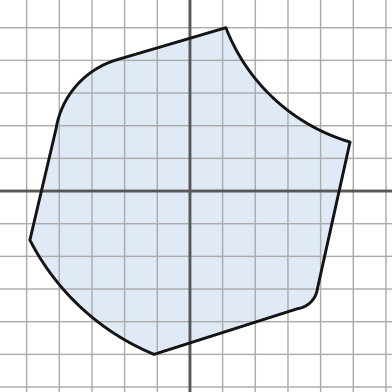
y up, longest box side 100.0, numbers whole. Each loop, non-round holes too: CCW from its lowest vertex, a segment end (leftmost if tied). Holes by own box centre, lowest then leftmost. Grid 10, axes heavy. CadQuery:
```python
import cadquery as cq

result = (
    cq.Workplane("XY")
    .moveTo(-11.0, -50.0)
    .lineTo(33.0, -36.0)
    .threePointArc((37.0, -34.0), (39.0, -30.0))
    .lineTo(49.0, 15.0)
    .threePointArc((26.0, 28.0), (11.0, 50.0))
    .lineTo(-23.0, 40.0)
    .threePointArc((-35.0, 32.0), (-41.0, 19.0))
    .lineTo(-49.0, -15.0)
    .threePointArc((-33.0, -36.0), (-11.0, -50.0))
    .close()
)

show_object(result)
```